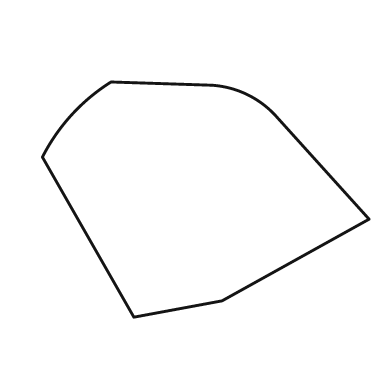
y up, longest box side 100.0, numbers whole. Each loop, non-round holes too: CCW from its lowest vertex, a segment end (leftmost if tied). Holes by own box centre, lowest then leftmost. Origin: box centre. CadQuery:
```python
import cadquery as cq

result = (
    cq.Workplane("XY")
    .moveTo(-22.0, -36.0)
    .lineTo(5.0, -31.0)
    .lineTo(50.0, -6.0)
    .lineTo(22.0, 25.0)
    .threePointArc((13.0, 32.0), (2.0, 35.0))
    .lineTo(-29.0, 36.0)
    .threePointArc((-41.0, 26.0), (-50.0, 13.0))
    .close()
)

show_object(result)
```